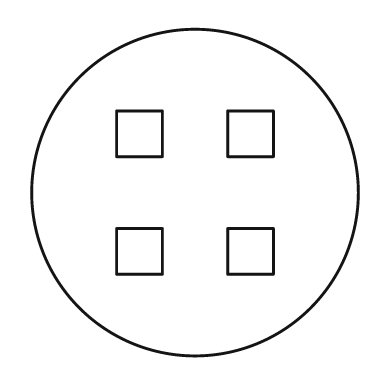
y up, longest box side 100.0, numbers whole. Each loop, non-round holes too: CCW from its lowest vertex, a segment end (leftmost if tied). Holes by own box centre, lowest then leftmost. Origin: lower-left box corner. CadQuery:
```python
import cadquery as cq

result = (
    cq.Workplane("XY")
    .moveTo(50.0, 50.0)
    .circle(50.0)
    .moveTo(26.0, 25.0)
    .lineTo(40.0, 25.0)
    .lineTo(40.0, 39.0)
    .lineTo(26.0, 39.0)
    .close()
    .moveTo(60.0, 25.0)
    .lineTo(74.0, 25.0)
    .lineTo(74.0, 39.0)
    .lineTo(60.0, 39.0)
    .close()
    .moveTo(26.0, 61.0)
    .lineTo(40.0, 61.0)
    .lineTo(40.0, 75.0)
    .lineTo(26.0, 75.0)
    .close()
    .moveTo(60.0, 61.0)
    .lineTo(74.0, 61.0)
    .lineTo(74.0, 75.0)
    .lineTo(60.0, 75.0)
    .close()
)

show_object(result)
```